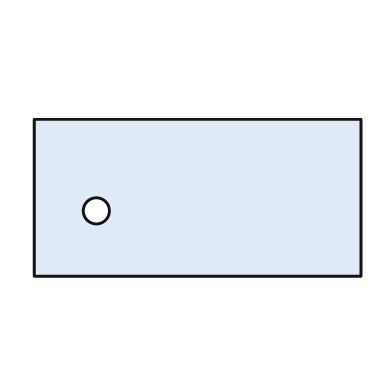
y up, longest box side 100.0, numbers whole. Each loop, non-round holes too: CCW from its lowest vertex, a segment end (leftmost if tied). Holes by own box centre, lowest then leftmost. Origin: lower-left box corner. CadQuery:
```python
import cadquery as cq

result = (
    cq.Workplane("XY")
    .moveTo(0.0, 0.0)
    .lineTo(100.0, 0.0)
    .lineTo(100.0, 48.0)
    .lineTo(0.0, 48.0)
    .close()
    .moveTo(19.0, 20.0)
    .circle(4.0)
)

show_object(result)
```